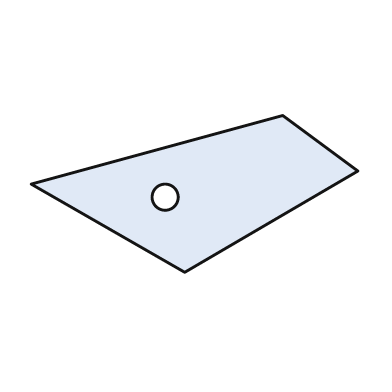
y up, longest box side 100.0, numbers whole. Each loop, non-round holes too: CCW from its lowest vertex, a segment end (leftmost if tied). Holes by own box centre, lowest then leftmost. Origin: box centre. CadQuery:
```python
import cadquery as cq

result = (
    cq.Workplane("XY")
    .moveTo(-3.0, -24.0)
    .lineTo(50.0, 7.0)
    .lineTo(27.0, 24.0)
    .lineTo(-50.0, 3.0)
    .close()
    .moveTo(-9.0, -1.0)
    .circle(4.0)
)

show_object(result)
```